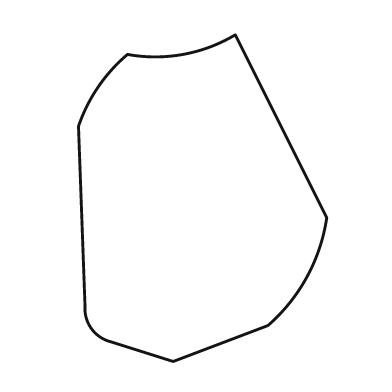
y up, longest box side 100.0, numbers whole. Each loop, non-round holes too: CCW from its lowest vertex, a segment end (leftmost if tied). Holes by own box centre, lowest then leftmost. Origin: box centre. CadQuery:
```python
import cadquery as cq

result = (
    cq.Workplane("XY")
    .moveTo(-9.0, -50.0)
    .lineTo(20.0, -39.0)
    .threePointArc((32.0, -24.0), (38.0, -6.0))
    .lineTo(10.0, 50.0)
    .threePointArc((-6.0, 44.0), (-23.0, 44.0))
    .threePointArc((-32.0, 34.0), (-38.0, 22.0))
    .lineTo(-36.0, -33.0)
    .threePointArc((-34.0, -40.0), (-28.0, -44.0))
    .close()
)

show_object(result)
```